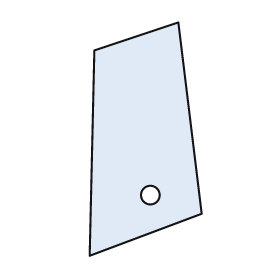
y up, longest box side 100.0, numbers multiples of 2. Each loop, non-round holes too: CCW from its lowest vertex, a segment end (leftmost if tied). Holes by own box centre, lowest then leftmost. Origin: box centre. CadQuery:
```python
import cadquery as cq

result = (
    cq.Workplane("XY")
    .moveTo(-24.0, -50.0)
    .lineTo(24.0, -32.0)
    .lineTo(14.0, 50.0)
    .lineTo(-22.0, 38.0)
    .close()
    .moveTo(2.0, -24.0)
    .circle(4.0)
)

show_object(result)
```